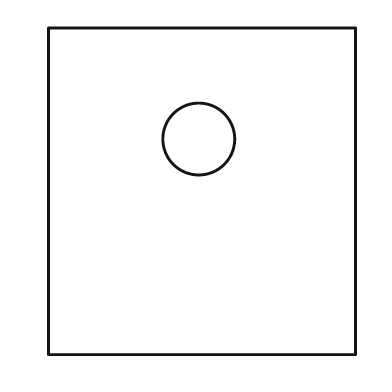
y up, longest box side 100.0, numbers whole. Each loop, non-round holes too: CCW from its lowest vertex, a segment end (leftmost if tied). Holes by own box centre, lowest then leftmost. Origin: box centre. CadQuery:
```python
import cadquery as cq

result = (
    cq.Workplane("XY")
    .moveTo(-47.0, -50.0)
    .lineTo(47.0, -50.0)
    .lineTo(47.0, 50.0)
    .lineTo(-47.0, 50.0)
    .close()
    .moveTo(-1.0, 16.0)
    .circle(11.0)
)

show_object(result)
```